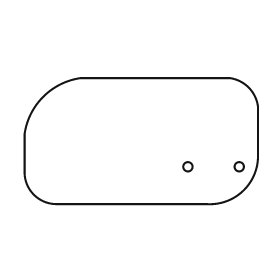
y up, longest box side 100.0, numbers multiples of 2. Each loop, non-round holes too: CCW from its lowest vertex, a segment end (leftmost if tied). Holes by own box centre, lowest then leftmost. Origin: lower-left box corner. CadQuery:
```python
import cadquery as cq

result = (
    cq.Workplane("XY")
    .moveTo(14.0, 0.0)
    .lineTo(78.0, 0.0)
    .threePointArc((94.0, 6.0), (100.0, 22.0))
    .lineTo(100.0, 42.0)
    .threePointArc((96.0, 50.0), (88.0, 54.0))
    .lineTo(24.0, 54.0)
    .threePointArc((8.0, 46.0), (0.0, 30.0))
    .lineTo(0.0, 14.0)
    .threePointArc((4.0, 4.0), (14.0, 0.0))
    .close()
    .moveTo(70.0, 16.0)
    .circle(2.0)
    .moveTo(92.0, 16.0)
    .circle(2.0)
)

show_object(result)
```